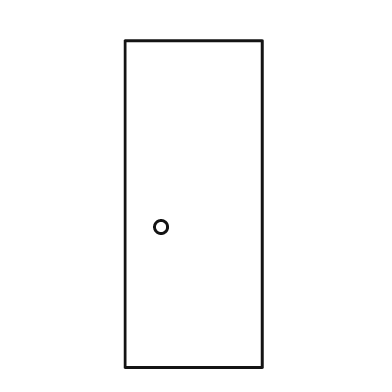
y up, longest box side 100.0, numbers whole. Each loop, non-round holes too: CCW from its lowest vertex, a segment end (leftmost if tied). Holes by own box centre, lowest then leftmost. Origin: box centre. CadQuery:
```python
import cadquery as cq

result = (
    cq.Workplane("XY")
    .moveTo(-21.0, -50.0)
    .lineTo(21.0, -50.0)
    .lineTo(21.0, 50.0)
    .lineTo(-21.0, 50.0)
    .close()
    .moveTo(-10.0, -7.0)
    .circle(2.0)
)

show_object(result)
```